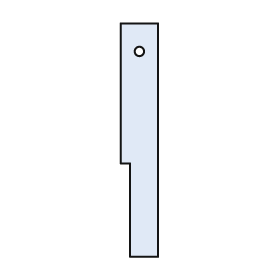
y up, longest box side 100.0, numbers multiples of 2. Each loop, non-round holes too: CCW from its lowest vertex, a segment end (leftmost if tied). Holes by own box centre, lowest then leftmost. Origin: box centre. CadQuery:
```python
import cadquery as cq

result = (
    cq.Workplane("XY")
    .moveTo(-4.0, -50.0)
    .lineTo(8.0, -50.0)
    .lineTo(8.0, 50.0)
    .lineTo(-8.0, 50.0)
    .lineTo(-8.0, -10.0)
    .lineTo(-4.0, -10.0)
    .close()
    .moveTo(0.0, 38.0)
    .circle(2.0)
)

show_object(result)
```